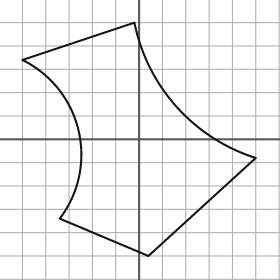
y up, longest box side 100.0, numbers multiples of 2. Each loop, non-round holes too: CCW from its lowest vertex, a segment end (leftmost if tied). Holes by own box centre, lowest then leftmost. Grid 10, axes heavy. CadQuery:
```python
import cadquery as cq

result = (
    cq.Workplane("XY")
    .moveTo(4.0, -50.0)
    .lineTo(50.0, -8.0)
    .threePointArc((16.0, 14.0), (-2.0, 50.0))
    .lineTo(-50.0, 34.0)
    .threePointArc((-26.0, 4.0), (-34.0, -34.0))
    .close()
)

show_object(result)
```